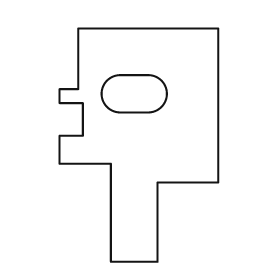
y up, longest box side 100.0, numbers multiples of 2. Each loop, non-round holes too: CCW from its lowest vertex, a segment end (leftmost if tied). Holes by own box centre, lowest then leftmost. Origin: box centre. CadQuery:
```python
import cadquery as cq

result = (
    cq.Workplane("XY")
    .moveTo(-12.0, -50.0)
    .lineTo(8.0, -50.0)
    .lineTo(8.0, -16.0)
    .lineTo(34.0, -16.0)
    .lineTo(34.0, 50.0)
    .lineTo(-26.0, 50.0)
    .lineTo(-26.0, 24.0)
    .lineTo(-34.0, 24.0)
    .lineTo(-34.0, 18.0)
    .lineTo(-24.0, 18.0)
    .lineTo(-24.0, 4.0)
    .lineTo(-34.0, 4.0)
    .lineTo(-34.0, -8.0)
    .lineTo(-12.0, -8.0)
    .close()
    .moveTo(-8.0, 14.0)
    .lineTo(4.0, 14.0)
    .threePointArc((12.0, 22.0), (4.0, 30.0))
    .lineTo(-8.0, 30.0)
    .threePointArc((-16.0, 22.0), (-8.0, 14.0))
    .close()
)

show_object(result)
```